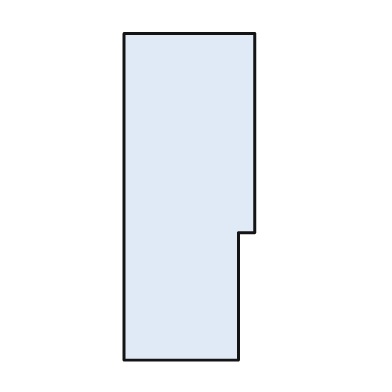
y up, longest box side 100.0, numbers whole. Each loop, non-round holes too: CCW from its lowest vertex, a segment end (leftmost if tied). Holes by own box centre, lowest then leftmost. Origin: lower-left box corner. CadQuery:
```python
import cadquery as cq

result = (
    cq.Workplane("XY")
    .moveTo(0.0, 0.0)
    .lineTo(35.0, 0.0)
    .lineTo(35.0, 39.0)
    .lineTo(40.0, 39.0)
    .lineTo(40.0, 100.0)
    .lineTo(0.0, 100.0)
    .close()
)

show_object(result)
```